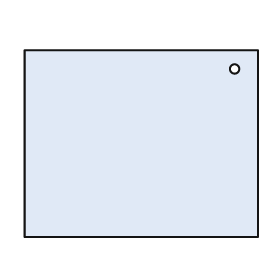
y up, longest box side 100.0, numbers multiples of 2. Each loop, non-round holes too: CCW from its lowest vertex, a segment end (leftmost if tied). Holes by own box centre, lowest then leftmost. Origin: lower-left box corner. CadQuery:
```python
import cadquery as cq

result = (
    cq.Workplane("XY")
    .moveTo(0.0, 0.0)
    .lineTo(100.0, 0.0)
    .lineTo(100.0, 80.0)
    .lineTo(0.0, 80.0)
    .close()
    .moveTo(90.0, 72.0)
    .circle(2.0)
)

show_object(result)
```